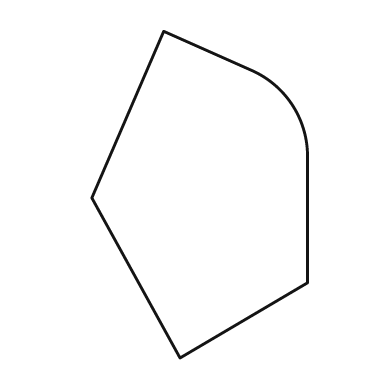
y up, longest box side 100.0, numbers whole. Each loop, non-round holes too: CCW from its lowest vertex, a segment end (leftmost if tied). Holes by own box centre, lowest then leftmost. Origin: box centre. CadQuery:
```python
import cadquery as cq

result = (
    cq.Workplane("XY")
    .moveTo(-6.0, -50.0)
    .lineTo(33.0, -27.0)
    .lineTo(33.0, 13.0)
    .threePointArc((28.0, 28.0), (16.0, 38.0))
    .lineTo(-11.0, 50.0)
    .lineTo(-33.0, -1.0)
    .close()
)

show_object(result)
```